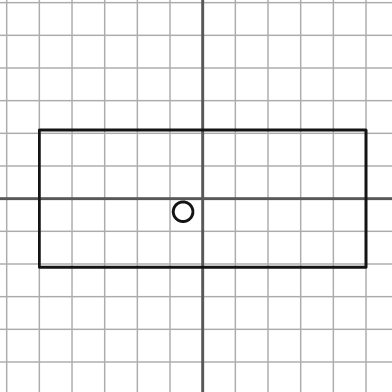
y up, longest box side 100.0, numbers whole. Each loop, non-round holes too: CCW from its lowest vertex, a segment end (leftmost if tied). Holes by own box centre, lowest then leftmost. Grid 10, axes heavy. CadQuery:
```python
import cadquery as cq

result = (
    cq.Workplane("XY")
    .moveTo(-50.0, -21.0)
    .lineTo(50.0, -21.0)
    .lineTo(50.0, 21.0)
    .lineTo(-50.0, 21.0)
    .close()
    .moveTo(-6.0, -4.0)
    .circle(3.0)
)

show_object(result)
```